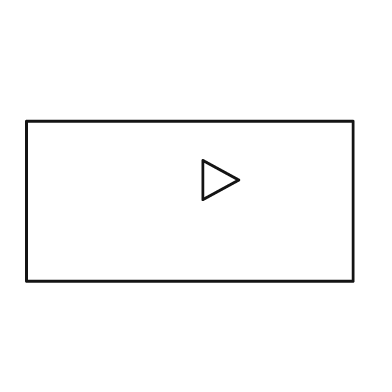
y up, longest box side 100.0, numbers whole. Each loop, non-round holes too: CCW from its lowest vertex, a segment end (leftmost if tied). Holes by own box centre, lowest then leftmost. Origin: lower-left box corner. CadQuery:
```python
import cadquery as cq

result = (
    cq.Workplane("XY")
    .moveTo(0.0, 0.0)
    .lineTo(100.0, 0.0)
    .lineTo(100.0, 49.0)
    .lineTo(0.0, 49.0)
    .close()
    .moveTo(54.0, 25.0)
    .lineTo(65.0, 31.0)
    .lineTo(54.0, 37.0)
    .close()
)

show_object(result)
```